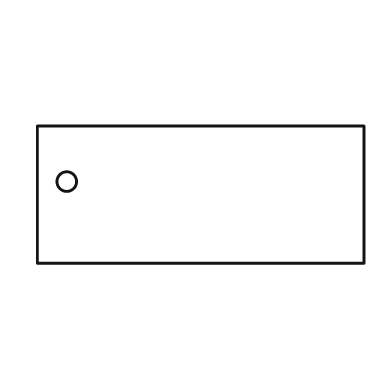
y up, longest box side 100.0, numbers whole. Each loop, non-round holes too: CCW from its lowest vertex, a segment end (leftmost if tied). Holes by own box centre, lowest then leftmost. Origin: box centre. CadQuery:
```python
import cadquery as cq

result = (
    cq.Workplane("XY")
    .moveTo(-50.0, -21.0)
    .lineTo(50.0, -21.0)
    .lineTo(50.0, 21.0)
    .lineTo(-50.0, 21.0)
    .close()
    .moveTo(-41.0, 4.0)
    .circle(3.0)
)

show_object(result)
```